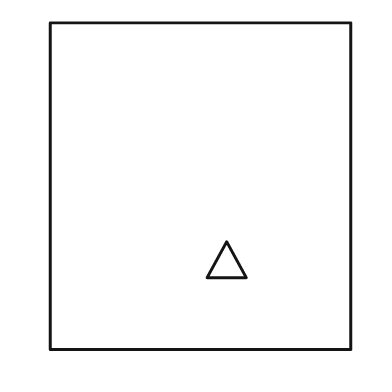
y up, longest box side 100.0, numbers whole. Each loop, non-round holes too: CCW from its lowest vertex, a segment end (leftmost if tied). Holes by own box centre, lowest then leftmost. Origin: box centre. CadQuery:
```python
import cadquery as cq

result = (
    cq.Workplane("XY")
    .moveTo(-46.0, -50.0)
    .lineTo(46.0, -50.0)
    .lineTo(46.0, 50.0)
    .lineTo(-46.0, 50.0)
    .close()
    .moveTo(2.0, -28.0)
    .lineTo(14.0, -28.0)
    .lineTo(8.0, -17.0)
    .close()
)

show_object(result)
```